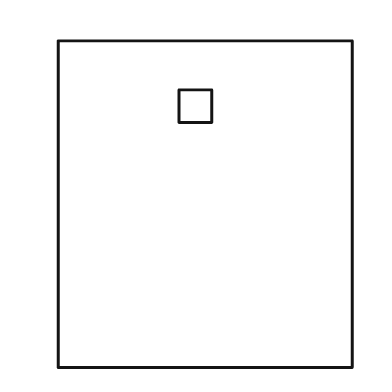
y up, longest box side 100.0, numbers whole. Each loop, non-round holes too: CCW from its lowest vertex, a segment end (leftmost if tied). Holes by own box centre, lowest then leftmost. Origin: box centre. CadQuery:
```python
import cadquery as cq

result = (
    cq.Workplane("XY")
    .moveTo(-45.0, -50.0)
    .lineTo(45.0, -50.0)
    .lineTo(45.0, 50.0)
    .lineTo(-45.0, 50.0)
    .close()
    .moveTo(-8.0, 25.0)
    .lineTo(2.0, 25.0)
    .lineTo(2.0, 35.0)
    .lineTo(-8.0, 35.0)
    .close()
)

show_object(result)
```